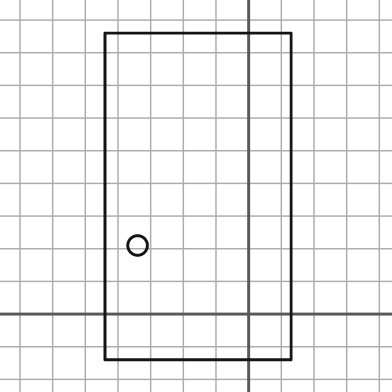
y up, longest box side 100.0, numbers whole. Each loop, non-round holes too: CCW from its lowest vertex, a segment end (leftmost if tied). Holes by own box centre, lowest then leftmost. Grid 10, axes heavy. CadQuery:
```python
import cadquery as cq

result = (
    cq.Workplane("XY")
    .moveTo(-44.0, -14.0)
    .lineTo(13.0, -14.0)
    .lineTo(13.0, 86.0)
    .lineTo(-44.0, 86.0)
    .close()
    .moveTo(-34.0, 21.0)
    .circle(3.0)
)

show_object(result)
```